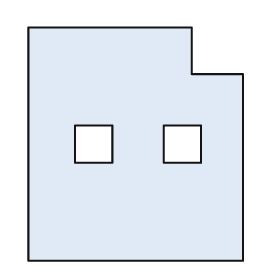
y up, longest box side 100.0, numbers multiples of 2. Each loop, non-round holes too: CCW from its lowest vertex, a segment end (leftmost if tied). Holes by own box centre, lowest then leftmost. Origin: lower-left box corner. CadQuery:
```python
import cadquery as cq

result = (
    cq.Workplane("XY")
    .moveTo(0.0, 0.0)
    .lineTo(92.0, 0.0)
    .lineTo(92.0, 80.0)
    .lineTo(70.0, 80.0)
    .lineTo(70.0, 100.0)
    .lineTo(0.0, 100.0)
    .close()
    .moveTo(20.0, 42.0)
    .lineTo(36.0, 42.0)
    .lineTo(36.0, 58.0)
    .lineTo(20.0, 58.0)
    .close()
    .moveTo(58.0, 42.0)
    .lineTo(74.0, 42.0)
    .lineTo(74.0, 58.0)
    .lineTo(58.0, 58.0)
    .close()
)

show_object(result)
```